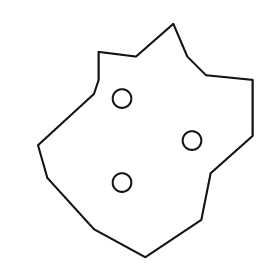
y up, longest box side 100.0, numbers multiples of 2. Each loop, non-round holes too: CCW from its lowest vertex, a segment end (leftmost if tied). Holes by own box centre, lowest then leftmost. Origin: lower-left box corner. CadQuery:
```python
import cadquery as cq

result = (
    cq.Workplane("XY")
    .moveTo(46.0, 0.0)
    .lineTo(70.0, 16.0)
    .lineTo(74.0, 36.0)
    .lineTo(92.0, 52.0)
    .lineTo(92.0, 76.0)
    .lineTo(72.0, 78.0)
    .lineTo(64.0, 86.0)
    .lineTo(58.0, 100.0)
    .lineTo(42.0, 86.0)
    .lineTo(26.0, 88.0)
    .lineTo(26.0, 76.0)
    .lineTo(24.0, 70.0)
    .lineTo(0.0, 48.0)
    .lineTo(4.0, 34.0)
    .lineTo(24.0, 12.0)
    .close()
    .moveTo(36.0, 32.0)
    .circle(4.0)
    .moveTo(66.0, 50.0)
    .circle(4.0)
    .moveTo(36.0, 68.0)
    .circle(4.0)
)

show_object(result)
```